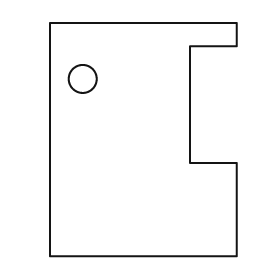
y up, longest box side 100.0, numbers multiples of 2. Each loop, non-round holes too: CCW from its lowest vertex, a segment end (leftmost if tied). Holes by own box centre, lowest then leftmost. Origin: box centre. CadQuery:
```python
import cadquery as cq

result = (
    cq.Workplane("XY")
    .moveTo(-40.0, -50.0)
    .lineTo(40.0, -50.0)
    .lineTo(40.0, -10.0)
    .lineTo(20.0, -10.0)
    .lineTo(20.0, 40.0)
    .lineTo(40.0, 40.0)
    .lineTo(40.0, 50.0)
    .lineTo(-40.0, 50.0)
    .close()
    .moveTo(-26.0, 26.0)
    .circle(6.0)
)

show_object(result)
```